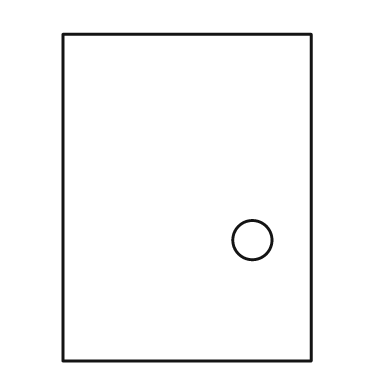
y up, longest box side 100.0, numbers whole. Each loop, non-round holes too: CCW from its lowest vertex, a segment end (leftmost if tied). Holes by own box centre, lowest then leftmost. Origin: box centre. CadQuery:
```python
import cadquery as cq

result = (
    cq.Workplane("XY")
    .moveTo(-38.0, -50.0)
    .lineTo(38.0, -50.0)
    .lineTo(38.0, 50.0)
    .lineTo(-38.0, 50.0)
    .close()
    .moveTo(20.0, -13.0)
    .circle(6.0)
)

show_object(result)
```